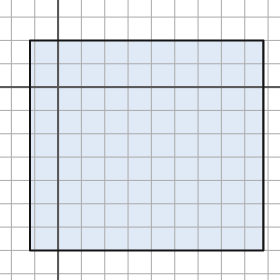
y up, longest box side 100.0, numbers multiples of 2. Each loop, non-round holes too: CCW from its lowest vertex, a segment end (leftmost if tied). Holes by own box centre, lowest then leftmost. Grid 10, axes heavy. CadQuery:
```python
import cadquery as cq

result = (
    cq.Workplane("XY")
    .moveTo(-12.0, -70.0)
    .lineTo(88.0, -70.0)
    .lineTo(88.0, 20.0)
    .lineTo(-12.0, 20.0)
    .close()
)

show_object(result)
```